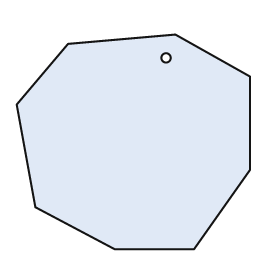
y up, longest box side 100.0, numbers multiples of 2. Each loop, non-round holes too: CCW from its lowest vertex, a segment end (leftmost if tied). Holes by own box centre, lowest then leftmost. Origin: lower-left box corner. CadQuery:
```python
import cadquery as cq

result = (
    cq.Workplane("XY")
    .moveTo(42.0, 0.0)
    .lineTo(76.0, 0.0)
    .lineTo(100.0, 34.0)
    .lineTo(100.0, 74.0)
    .lineTo(68.0, 92.0)
    .lineTo(22.0, 88.0)
    .lineTo(0.0, 62.0)
    .lineTo(8.0, 18.0)
    .close()
    .moveTo(64.0, 82.0)
    .circle(2.0)
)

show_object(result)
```